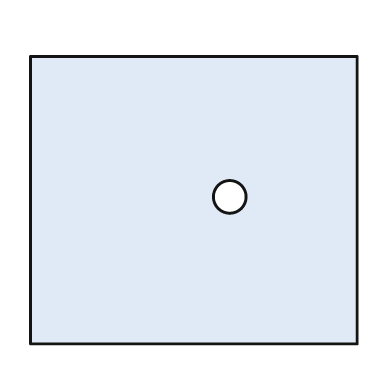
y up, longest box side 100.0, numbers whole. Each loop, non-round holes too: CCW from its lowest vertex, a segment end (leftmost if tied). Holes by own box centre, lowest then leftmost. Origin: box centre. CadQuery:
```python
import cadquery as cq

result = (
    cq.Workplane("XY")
    .moveTo(-50.0, -44.0)
    .lineTo(50.0, -44.0)
    .lineTo(50.0, 44.0)
    .lineTo(-50.0, 44.0)
    .close()
    .moveTo(11.0, 1.0)
    .circle(5.0)
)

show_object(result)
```